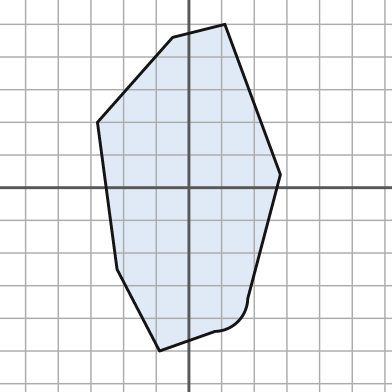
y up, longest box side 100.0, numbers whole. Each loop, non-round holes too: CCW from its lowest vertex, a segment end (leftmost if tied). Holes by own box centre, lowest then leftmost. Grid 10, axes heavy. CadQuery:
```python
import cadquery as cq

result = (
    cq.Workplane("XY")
    .moveTo(-9.0, -50.0)
    .lineTo(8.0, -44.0)
    .threePointArc((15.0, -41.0), (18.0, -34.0))
    .lineTo(28.0, 4.0)
    .lineTo(11.0, 50.0)
    .lineTo(-5.0, 46.0)
    .lineTo(-28.0, 20.0)
    .lineTo(-22.0, -25.0)
    .close()
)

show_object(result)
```